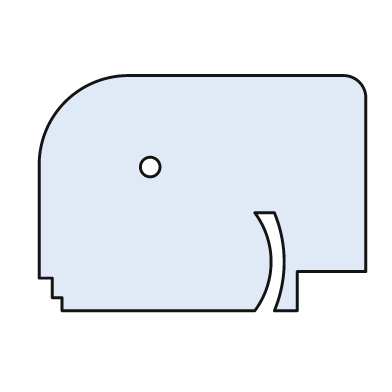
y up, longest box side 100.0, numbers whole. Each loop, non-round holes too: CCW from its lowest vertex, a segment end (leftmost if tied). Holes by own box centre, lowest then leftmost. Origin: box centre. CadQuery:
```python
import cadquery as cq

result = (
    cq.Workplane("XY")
    .moveTo(-43.0, -36.0)
    .lineTo(16.0, -36.0)
    .threePointArc((21.0, -21.0), (16.0, -6.0))
    .lineTo(22.0, -6.0)
    .threePointArc((25.0, -21.0), (22.0, -36.0))
    .lineTo(29.0, -36.0)
    .lineTo(29.0, -24.0)
    .lineTo(50.0, -24.0)
    .lineTo(50.0, 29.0)
    .threePointArc((48.0, 34.0), (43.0, 36.0))
    .lineTo(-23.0, 36.0)
    .threePointArc((-42.0, 28.0), (-50.0, 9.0))
    .lineTo(-50.0, -26.0)
    .lineTo(-46.0, -26.0)
    .lineTo(-46.0, -32.0)
    .lineTo(-43.0, -32.0)
    .close()
    .moveTo(-16.0, 8.0)
    .circle(3.0)
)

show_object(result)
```